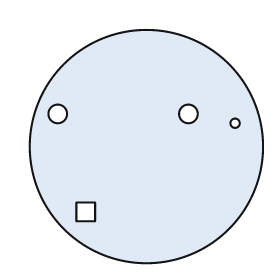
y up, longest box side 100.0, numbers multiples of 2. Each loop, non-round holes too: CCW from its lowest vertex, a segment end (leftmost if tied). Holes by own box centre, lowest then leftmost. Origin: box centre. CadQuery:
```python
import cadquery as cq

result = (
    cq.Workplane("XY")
    .moveTo(0.0, 0.0)
    .circle(50.0)
    .moveTo(-30.0, -32.0)
    .lineTo(-22.0, -32.0)
    .lineTo(-22.0, -24.0)
    .lineTo(-30.0, -24.0)
    .close()
    .moveTo(38.0, 10.0)
    .circle(2.0)
    .moveTo(-38.0, 14.0)
    .circle(4.0)
    .moveTo(18.0, 14.0)
    .circle(4.0)
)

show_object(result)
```